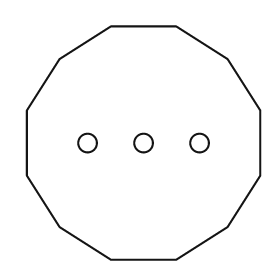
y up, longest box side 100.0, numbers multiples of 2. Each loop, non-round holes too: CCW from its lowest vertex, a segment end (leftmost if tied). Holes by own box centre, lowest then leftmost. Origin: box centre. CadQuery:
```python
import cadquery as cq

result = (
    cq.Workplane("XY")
    .moveTo(-14.0, -50.0)
    .lineTo(14.0, -50.0)
    .lineTo(36.0, -36.0)
    .lineTo(50.0, -14.0)
    .lineTo(50.0, 14.0)
    .lineTo(36.0, 36.0)
    .lineTo(14.0, 50.0)
    .lineTo(-14.0, 50.0)
    .lineTo(-36.0, 36.0)
    .lineTo(-50.0, 14.0)
    .lineTo(-50.0, -14.0)
    .lineTo(-36.0, -36.0)
    .close()
    .moveTo(-24.0, 0.0)
    .circle(4.0)
    .moveTo(0.0, 0.0)
    .circle(4.0)
    .moveTo(24.0, 0.0)
    .circle(4.0)
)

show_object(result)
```